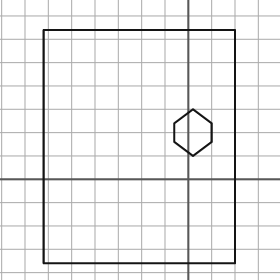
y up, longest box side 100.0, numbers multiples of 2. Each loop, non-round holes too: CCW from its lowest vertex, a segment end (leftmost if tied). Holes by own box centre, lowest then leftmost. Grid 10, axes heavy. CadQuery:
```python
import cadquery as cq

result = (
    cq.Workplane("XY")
    .moveTo(-62.0, -36.0)
    .lineTo(20.0, -36.0)
    .lineTo(20.0, 64.0)
    .lineTo(-62.0, 64.0)
    .close()
    .moveTo(2.0, 10.0)
    .lineTo(10.0, 16.0)
    .lineTo(10.0, 24.0)
    .lineTo(2.0, 30.0)
    .lineTo(-6.0, 24.0)
    .lineTo(-6.0, 16.0)
    .close()
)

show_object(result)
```